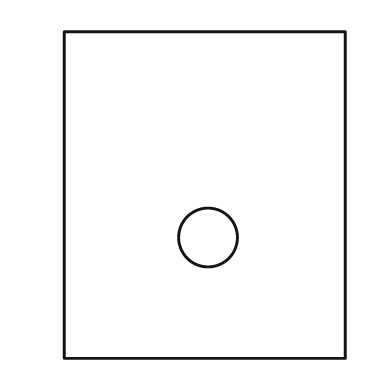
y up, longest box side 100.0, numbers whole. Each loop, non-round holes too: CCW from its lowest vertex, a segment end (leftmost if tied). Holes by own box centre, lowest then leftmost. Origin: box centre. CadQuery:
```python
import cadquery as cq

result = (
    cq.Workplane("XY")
    .moveTo(-43.0, -50.0)
    .lineTo(43.0, -50.0)
    .lineTo(43.0, 50.0)
    .lineTo(-43.0, 50.0)
    .close()
    .moveTo(1.0, -13.0)
    .circle(9.0)
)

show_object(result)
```